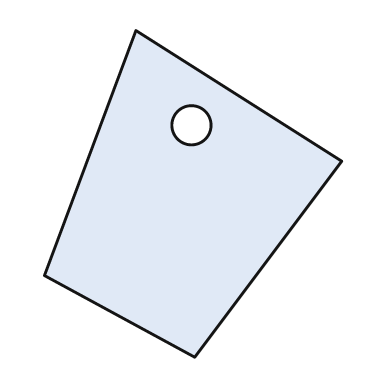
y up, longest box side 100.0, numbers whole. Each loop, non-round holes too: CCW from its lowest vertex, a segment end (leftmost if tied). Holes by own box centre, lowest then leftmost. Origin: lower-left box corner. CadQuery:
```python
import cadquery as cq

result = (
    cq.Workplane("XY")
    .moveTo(46.0, 0.0)
    .lineTo(91.0, 60.0)
    .lineTo(28.0, 100.0)
    .lineTo(0.0, 25.0)
    .close()
    .moveTo(45.0, 71.0)
    .circle(6.0)
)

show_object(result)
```